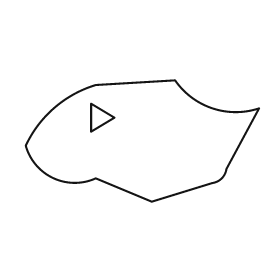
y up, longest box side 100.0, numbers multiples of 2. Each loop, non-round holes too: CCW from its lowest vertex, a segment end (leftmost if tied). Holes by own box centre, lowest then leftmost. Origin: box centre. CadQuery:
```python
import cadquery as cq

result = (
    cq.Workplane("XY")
    .moveTo(4.0, -26.0)
    .lineTo(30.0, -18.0)
    .threePointArc((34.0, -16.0), (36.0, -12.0))
    .lineTo(50.0, 14.0)
    .threePointArc((30.0, 14.0), (14.0, 26.0))
    .lineTo(-20.0, 24.0)
    .threePointArc((-38.0, 14.0), (-50.0, -2.0))
    .threePointArc((-38.0, -16.0), (-20.0, -16.0))
    .close()
    .moveTo(-22.0, 4.0)
    .lineTo(-12.0, 10.0)
    .lineTo(-22.0, 16.0)
    .close()
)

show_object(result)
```